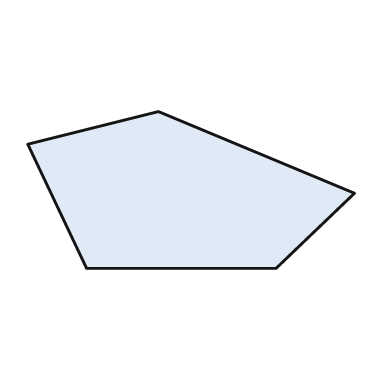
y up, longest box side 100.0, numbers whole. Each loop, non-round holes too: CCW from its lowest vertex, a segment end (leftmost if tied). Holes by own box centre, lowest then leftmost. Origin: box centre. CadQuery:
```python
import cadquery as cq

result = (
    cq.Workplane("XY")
    .moveTo(-32.0, -24.0)
    .lineTo(26.0, -24.0)
    .lineTo(50.0, -1.0)
    .lineTo(-10.0, 24.0)
    .lineTo(-50.0, 14.0)
    .close()
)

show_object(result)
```